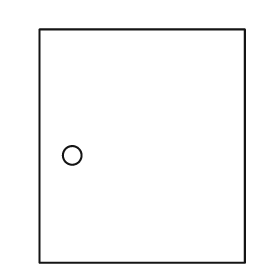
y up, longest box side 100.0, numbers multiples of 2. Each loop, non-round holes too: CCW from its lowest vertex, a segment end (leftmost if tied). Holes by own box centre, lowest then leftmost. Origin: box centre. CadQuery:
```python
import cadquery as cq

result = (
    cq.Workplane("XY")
    .moveTo(-44.0, -50.0)
    .lineTo(44.0, -50.0)
    .lineTo(44.0, 50.0)
    .lineTo(-44.0, 50.0)
    .close()
    .moveTo(-30.0, -4.0)
    .circle(4.0)
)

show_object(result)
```